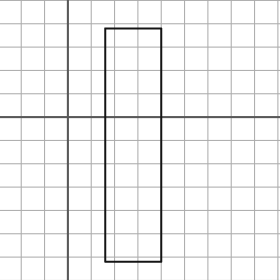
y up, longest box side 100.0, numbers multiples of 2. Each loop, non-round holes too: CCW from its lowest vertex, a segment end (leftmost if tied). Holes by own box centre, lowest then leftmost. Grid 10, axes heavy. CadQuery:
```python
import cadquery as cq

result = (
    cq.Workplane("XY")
    .moveTo(16.0, -62.0)
    .lineTo(40.0, -62.0)
    .lineTo(40.0, 38.0)
    .lineTo(16.0, 38.0)
    .close()
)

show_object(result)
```